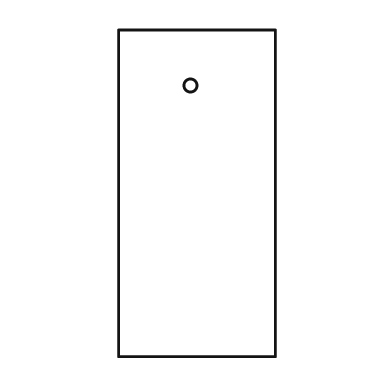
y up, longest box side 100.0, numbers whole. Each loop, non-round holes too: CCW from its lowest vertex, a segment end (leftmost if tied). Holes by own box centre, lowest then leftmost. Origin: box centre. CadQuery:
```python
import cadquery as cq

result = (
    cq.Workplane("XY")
    .moveTo(-24.0, -50.0)
    .lineTo(24.0, -50.0)
    .lineTo(24.0, 50.0)
    .lineTo(-24.0, 50.0)
    .close()
    .moveTo(-2.0, 33.0)
    .circle(2.0)
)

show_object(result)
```